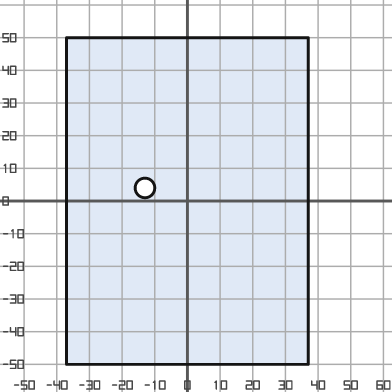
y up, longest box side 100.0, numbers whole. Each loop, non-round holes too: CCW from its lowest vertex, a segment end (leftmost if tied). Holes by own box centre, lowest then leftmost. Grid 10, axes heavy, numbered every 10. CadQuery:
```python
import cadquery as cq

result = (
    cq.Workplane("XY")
    .moveTo(-37.0, -50.0)
    .lineTo(37.0, -50.0)
    .lineTo(37.0, 50.0)
    .lineTo(-37.0, 50.0)
    .close()
    .moveTo(-13.0, 4.0)
    .circle(3.0)
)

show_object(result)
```